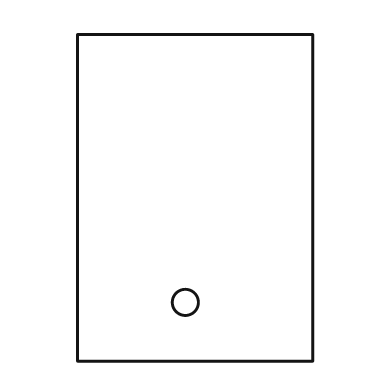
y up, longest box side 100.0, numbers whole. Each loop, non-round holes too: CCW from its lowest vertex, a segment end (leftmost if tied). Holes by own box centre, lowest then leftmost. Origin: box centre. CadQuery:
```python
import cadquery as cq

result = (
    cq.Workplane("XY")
    .moveTo(-36.0, -50.0)
    .lineTo(36.0, -50.0)
    .lineTo(36.0, 50.0)
    .lineTo(-36.0, 50.0)
    .close()
    .moveTo(-3.0, -32.0)
    .circle(4.0)
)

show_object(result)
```